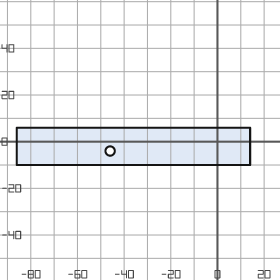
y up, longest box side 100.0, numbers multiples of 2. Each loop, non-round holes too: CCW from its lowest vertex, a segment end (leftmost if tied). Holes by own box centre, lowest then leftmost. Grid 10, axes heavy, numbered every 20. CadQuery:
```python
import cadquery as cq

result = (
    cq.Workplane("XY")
    .moveTo(-86.0, -10.0)
    .lineTo(14.0, -10.0)
    .lineTo(14.0, 6.0)
    .lineTo(-86.0, 6.0)
    .close()
    .moveTo(-46.0, -4.0)
    .circle(2.0)
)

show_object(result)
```